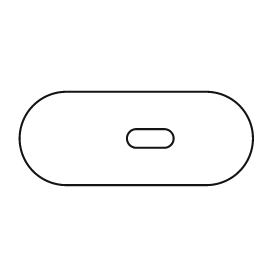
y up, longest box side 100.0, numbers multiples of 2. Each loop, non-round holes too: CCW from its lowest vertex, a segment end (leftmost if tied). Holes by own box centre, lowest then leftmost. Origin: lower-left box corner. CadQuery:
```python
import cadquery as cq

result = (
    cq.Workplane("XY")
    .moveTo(20.0, 0.0)
    .lineTo(80.0, 0.0)
    .threePointArc((100.0, 20.0), (80.0, 40.0))
    .lineTo(20.0, 40.0)
    .threePointArc((0.0, 20.0), (20.0, 0.0))
    .close()
    .moveTo(50.0, 16.0)
    .lineTo(62.0, 16.0)
    .threePointArc((66.0, 20.0), (62.0, 24.0))
    .lineTo(50.0, 24.0)
    .threePointArc((46.0, 20.0), (50.0, 16.0))
    .close()
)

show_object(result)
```